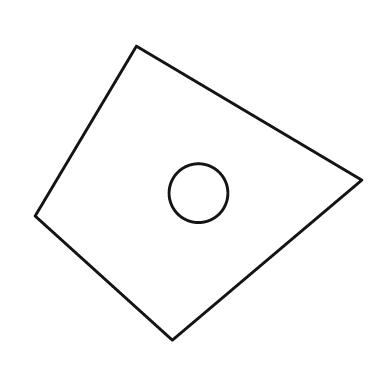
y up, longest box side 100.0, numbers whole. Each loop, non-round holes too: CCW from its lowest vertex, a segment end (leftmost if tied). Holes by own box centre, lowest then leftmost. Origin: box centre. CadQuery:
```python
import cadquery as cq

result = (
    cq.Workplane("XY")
    .moveTo(-8.0, -45.0)
    .lineTo(50.0, 4.0)
    .lineTo(-19.0, 45.0)
    .lineTo(-50.0, -7.0)
    .close()
    .moveTo(0.0, 0.0)
    .circle(9.0)
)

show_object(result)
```